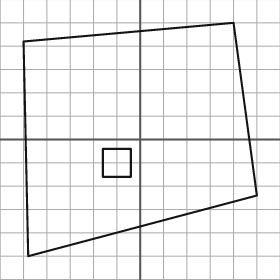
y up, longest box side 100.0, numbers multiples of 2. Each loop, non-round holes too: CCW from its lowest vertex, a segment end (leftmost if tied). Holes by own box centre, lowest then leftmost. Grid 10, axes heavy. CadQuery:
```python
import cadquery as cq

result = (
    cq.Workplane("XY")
    .moveTo(-48.0, -50.0)
    .lineTo(50.0, -24.0)
    .lineTo(40.0, 50.0)
    .lineTo(-50.0, 42.0)
    .close()
    .moveTo(-16.0, -16.0)
    .lineTo(-4.0, -16.0)
    .lineTo(-4.0, -4.0)
    .lineTo(-16.0, -4.0)
    .close()
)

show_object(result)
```